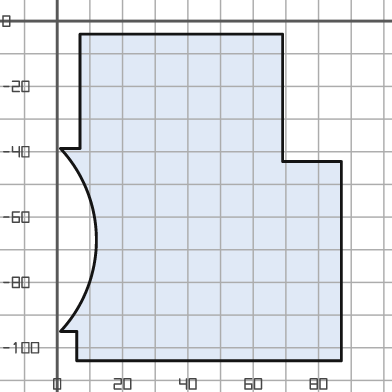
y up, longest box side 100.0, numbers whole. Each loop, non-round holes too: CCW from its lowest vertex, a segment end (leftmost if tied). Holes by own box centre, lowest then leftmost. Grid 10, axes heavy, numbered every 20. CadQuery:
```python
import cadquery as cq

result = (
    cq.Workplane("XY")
    .moveTo(6.0, -104.0)
    .lineTo(87.0, -104.0)
    .lineTo(87.0, -43.0)
    .lineTo(69.0, -43.0)
    .lineTo(69.0, -4.0)
    .lineTo(7.0, -4.0)
    .lineTo(7.0, -39.0)
    .lineTo(1.0, -39.0)
    .threePointArc((12.0, -67.0), (1.0, -95.0))
    .lineTo(6.0, -95.0)
    .close()
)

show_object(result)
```